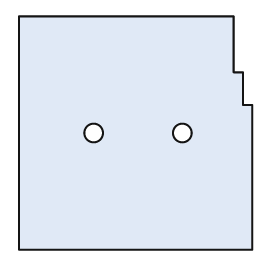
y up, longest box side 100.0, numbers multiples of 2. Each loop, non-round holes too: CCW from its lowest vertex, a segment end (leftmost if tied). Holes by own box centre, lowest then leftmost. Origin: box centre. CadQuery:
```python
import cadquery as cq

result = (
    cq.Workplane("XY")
    .moveTo(-50.0, -50.0)
    .lineTo(50.0, -50.0)
    .lineTo(50.0, 12.0)
    .lineTo(46.0, 12.0)
    .lineTo(46.0, 26.0)
    .lineTo(42.0, 26.0)
    .lineTo(42.0, 50.0)
    .lineTo(-50.0, 50.0)
    .close()
    .moveTo(-18.0, 0.0)
    .circle(4.0)
    .moveTo(20.0, 0.0)
    .circle(4.0)
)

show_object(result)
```